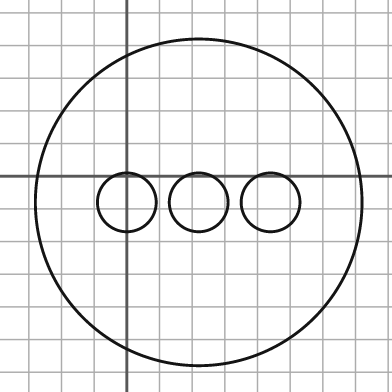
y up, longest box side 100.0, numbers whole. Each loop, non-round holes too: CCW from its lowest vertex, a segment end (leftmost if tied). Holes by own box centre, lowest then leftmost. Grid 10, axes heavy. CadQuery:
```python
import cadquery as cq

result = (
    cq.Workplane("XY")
    .moveTo(22.0, -8.0)
    .circle(50.0)
    .moveTo(0.0, -8.0)
    .circle(9.0)
    .moveTo(22.0, -8.0)
    .circle(9.0)
    .moveTo(44.0, -8.0)
    .circle(9.0)
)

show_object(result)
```